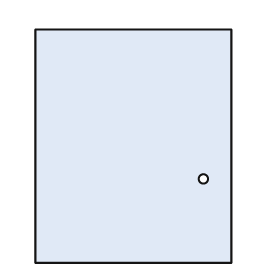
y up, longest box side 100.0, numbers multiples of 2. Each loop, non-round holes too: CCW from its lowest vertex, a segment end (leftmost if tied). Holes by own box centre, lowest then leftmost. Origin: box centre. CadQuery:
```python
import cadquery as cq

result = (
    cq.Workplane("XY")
    .moveTo(-42.0, -50.0)
    .lineTo(42.0, -50.0)
    .lineTo(42.0, 50.0)
    .lineTo(-42.0, 50.0)
    .close()
    .moveTo(30.0, -14.0)
    .circle(2.0)
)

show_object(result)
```